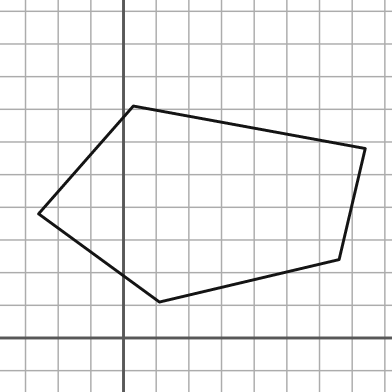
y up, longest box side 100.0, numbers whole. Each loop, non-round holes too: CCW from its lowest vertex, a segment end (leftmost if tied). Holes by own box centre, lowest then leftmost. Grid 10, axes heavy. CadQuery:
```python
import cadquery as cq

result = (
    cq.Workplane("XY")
    .moveTo(11.0, 11.0)
    .lineTo(66.0, 24.0)
    .lineTo(74.0, 58.0)
    .lineTo(3.0, 71.0)
    .lineTo(-26.0, 38.0)
    .close()
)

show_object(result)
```